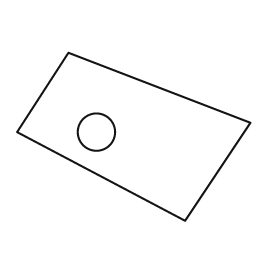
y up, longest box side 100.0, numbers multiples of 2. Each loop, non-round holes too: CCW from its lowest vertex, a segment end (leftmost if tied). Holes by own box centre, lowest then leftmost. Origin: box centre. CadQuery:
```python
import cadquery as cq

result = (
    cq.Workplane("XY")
    .moveTo(22.0, -36.0)
    .lineTo(50.0, 6.0)
    .lineTo(-28.0, 36.0)
    .lineTo(-50.0, 2.0)
    .close()
    .moveTo(-16.0, 2.0)
    .circle(8.0)
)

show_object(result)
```